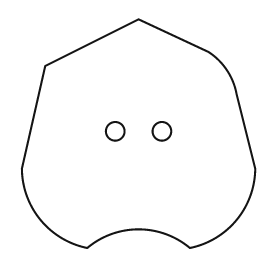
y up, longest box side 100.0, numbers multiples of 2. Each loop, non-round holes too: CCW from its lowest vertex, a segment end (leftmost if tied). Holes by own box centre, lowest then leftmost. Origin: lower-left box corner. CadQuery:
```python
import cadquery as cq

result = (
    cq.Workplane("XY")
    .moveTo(28.0, 0.0)
    .threePointArc((50.0, 8.0), (72.0, 0.0))
    .threePointArc((92.0, 12.0), (100.0, 34.0))
    .lineTo(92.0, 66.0)
    .threePointArc((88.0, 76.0), (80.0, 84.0))
    .lineTo(50.0, 98.0)
    .lineTo(10.0, 78.0)
    .lineTo(0.0, 34.0)
    .threePointArc((8.0, 12.0), (28.0, 0.0))
    .close()
    .moveTo(40.0, 50.0)
    .circle(4.0)
    .moveTo(60.0, 50.0)
    .circle(4.0)
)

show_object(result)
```